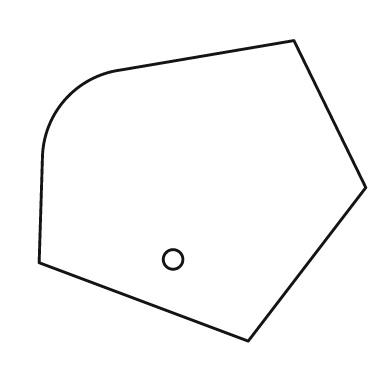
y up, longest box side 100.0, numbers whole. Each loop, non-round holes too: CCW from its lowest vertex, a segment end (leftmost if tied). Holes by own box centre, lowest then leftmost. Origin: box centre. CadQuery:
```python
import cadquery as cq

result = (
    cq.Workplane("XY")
    .moveTo(14.0, -46.0)
    .lineTo(50.0, 1.0)
    .lineTo(28.0, 46.0)
    .lineTo(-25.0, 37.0)
    .threePointArc((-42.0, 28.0), (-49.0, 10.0))
    .lineTo(-50.0, -22.0)
    .close()
    .moveTo(-9.0, -21.0)
    .circle(3.0)
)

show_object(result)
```